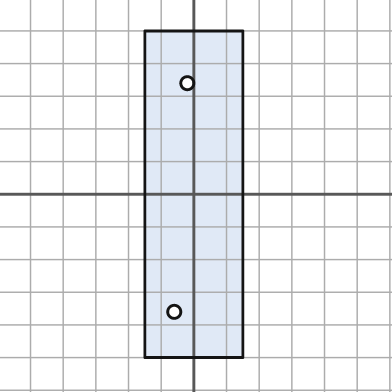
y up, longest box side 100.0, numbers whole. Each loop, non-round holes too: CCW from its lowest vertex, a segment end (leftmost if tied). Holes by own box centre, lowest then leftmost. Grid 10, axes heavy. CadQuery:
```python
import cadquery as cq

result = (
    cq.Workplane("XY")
    .moveTo(-15.0, -50.0)
    .lineTo(15.0, -50.0)
    .lineTo(15.0, 50.0)
    .lineTo(-15.0, 50.0)
    .close()
    .moveTo(-6.0, -36.0)
    .circle(2.0)
    .moveTo(-2.0, 34.0)
    .circle(2.0)
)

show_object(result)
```